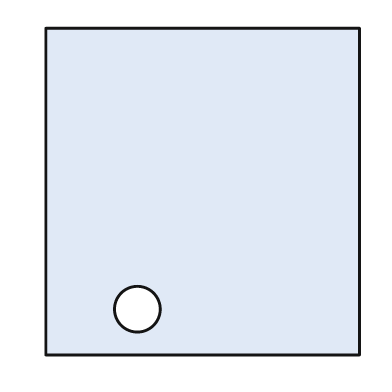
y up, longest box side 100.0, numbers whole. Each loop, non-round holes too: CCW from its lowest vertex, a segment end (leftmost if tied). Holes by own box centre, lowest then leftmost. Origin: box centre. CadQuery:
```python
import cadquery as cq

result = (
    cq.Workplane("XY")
    .moveTo(-48.0, -50.0)
    .lineTo(48.0, -50.0)
    .lineTo(48.0, 50.0)
    .lineTo(-48.0, 50.0)
    .close()
    .moveTo(-20.0, -36.0)
    .circle(7.0)
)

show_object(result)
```